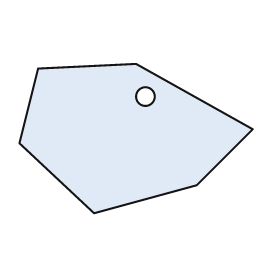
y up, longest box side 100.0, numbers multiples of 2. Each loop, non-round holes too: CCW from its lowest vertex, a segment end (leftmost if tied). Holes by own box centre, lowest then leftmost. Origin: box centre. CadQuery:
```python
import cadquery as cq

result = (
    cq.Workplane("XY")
    .moveTo(-18.0, -32.0)
    .lineTo(26.0, -20.0)
    .lineTo(50.0, 4.0)
    .lineTo(0.0, 32.0)
    .lineTo(-42.0, 30.0)
    .lineTo(-50.0, -2.0)
    .close()
    .moveTo(4.0, 18.0)
    .circle(4.0)
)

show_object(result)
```